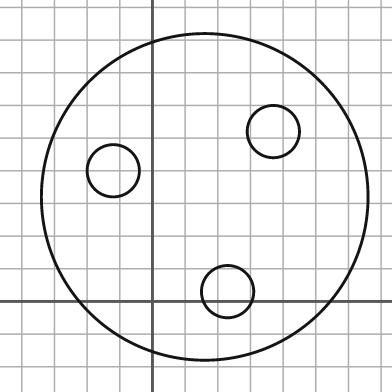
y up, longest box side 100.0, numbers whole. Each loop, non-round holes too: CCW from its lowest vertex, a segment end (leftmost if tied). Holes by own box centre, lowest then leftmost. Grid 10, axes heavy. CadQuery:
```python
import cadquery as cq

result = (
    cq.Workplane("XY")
    .moveTo(16.0, 32.0)
    .circle(50.0)
    .moveTo(23.0, 3.0)
    .circle(8.0)
    .moveTo(-12.0, 40.0)
    .circle(8.0)
    .moveTo(37.0, 52.0)
    .circle(8.0)
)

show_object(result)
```